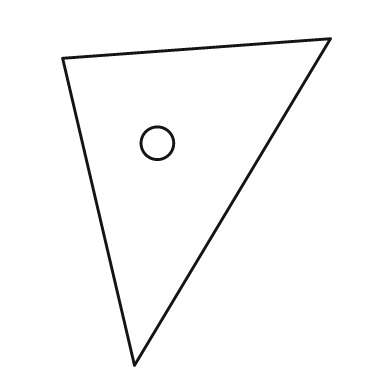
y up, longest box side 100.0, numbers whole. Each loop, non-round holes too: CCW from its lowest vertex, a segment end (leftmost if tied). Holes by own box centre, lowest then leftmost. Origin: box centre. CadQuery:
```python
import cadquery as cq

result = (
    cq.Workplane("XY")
    .moveTo(-19.0, -50.0)
    .lineTo(41.0, 50.0)
    .lineTo(-41.0, 44.0)
    .close()
    .moveTo(-12.0, 18.0)
    .circle(5.0)
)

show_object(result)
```